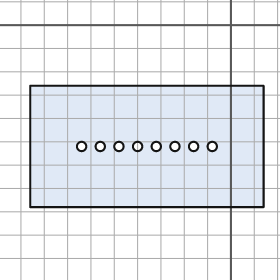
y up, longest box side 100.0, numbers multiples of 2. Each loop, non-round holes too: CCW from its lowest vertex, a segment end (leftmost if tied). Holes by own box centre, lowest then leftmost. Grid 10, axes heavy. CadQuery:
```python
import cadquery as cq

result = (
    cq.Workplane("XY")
    .moveTo(-86.0, -78.0)
    .lineTo(14.0, -78.0)
    .lineTo(14.0, -26.0)
    .lineTo(-86.0, -26.0)
    .close()
    .moveTo(-64.0, -52.0)
    .circle(2.0)
    .moveTo(-56.0, -52.0)
    .circle(2.0)
    .moveTo(-48.0, -52.0)
    .circle(2.0)
    .moveTo(-40.0, -52.0)
    .circle(2.0)
    .moveTo(-32.0, -52.0)
    .circle(2.0)
    .moveTo(-24.0, -52.0)
    .circle(2.0)
    .moveTo(-16.0, -52.0)
    .circle(2.0)
    .moveTo(-8.0, -52.0)
    .circle(2.0)
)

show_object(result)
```